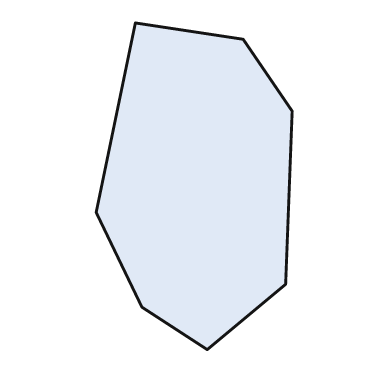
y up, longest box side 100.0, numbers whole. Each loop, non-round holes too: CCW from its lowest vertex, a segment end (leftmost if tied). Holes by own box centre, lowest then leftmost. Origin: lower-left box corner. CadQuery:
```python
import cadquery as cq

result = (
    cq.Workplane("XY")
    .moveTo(34.0, 0.0)
    .lineTo(58.0, 20.0)
    .lineTo(60.0, 73.0)
    .lineTo(45.0, 95.0)
    .lineTo(12.0, 100.0)
    .lineTo(0.0, 42.0)
    .lineTo(14.0, 13.0)
    .close()
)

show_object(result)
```